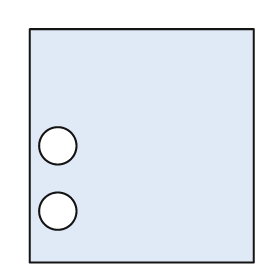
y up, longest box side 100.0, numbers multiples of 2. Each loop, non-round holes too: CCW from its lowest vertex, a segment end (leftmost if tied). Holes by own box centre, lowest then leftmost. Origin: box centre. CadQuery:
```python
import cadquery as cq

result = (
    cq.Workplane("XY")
    .moveTo(-48.0, -50.0)
    .lineTo(48.0, -50.0)
    .lineTo(48.0, 50.0)
    .lineTo(-48.0, 50.0)
    .close()
    .moveTo(-36.0, -28.0)
    .circle(8.0)
    .moveTo(-36.0, 0.0)
    .circle(8.0)
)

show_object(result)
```